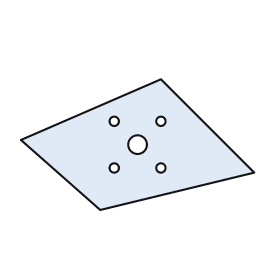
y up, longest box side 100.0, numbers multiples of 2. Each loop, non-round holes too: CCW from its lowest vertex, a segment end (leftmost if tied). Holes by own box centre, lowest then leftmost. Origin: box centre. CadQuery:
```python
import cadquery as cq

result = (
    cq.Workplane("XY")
    .moveTo(-16.0, -28.0)
    .lineTo(50.0, -12.0)
    .lineTo(10.0, 28.0)
    .lineTo(-50.0, 2.0)
    .close()
    .moveTo(-10.0, -10.0)
    .circle(2.0)
    .moveTo(10.0, -10.0)
    .circle(2.0)
    .moveTo(0.0, 0.0)
    .circle(4.0)
    .moveTo(-10.0, 10.0)
    .circle(2.0)
    .moveTo(10.0, 10.0)
    .circle(2.0)
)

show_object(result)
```